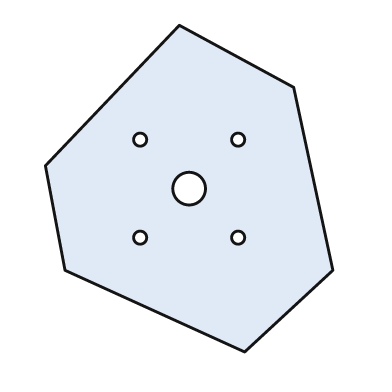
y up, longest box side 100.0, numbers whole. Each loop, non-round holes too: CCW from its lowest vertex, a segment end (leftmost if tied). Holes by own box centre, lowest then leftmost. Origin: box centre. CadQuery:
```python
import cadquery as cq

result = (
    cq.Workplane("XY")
    .moveTo(17.0, -50.0)
    .lineTo(44.0, -25.0)
    .lineTo(32.0, 31.0)
    .lineTo(-3.0, 50.0)
    .lineTo(-44.0, 7.0)
    .lineTo(-38.0, -25.0)
    .close()
    .moveTo(-15.0, -15.0)
    .circle(2.0)
    .moveTo(15.0, -15.0)
    .circle(2.0)
    .moveTo(0.0, 0.0)
    .circle(5.0)
    .moveTo(-15.0, 15.0)
    .circle(2.0)
    .moveTo(15.0, 15.0)
    .circle(2.0)
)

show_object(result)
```